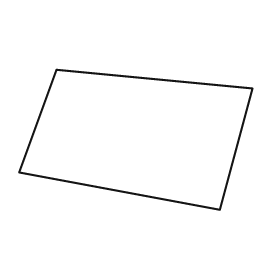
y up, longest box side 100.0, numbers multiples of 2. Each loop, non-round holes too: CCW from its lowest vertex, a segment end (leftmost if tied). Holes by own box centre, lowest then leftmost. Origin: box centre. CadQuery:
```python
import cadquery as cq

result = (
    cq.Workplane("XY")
    .moveTo(36.0, -30.0)
    .lineTo(50.0, 22.0)
    .lineTo(-34.0, 30.0)
    .lineTo(-50.0, -14.0)
    .close()
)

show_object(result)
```